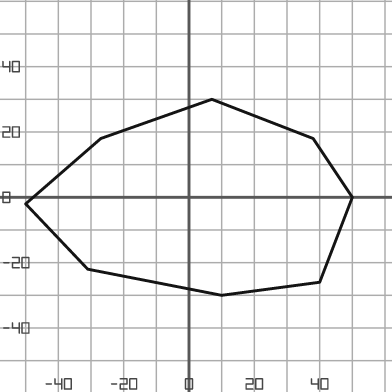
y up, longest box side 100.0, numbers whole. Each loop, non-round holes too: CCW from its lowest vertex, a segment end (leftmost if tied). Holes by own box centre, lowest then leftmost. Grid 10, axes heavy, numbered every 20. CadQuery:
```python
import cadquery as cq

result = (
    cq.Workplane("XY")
    .moveTo(10.0, -30.0)
    .lineTo(40.0, -26.0)
    .lineTo(50.0, 0.0)
    .lineTo(38.0, 18.0)
    .lineTo(7.0, 30.0)
    .lineTo(-27.0, 18.0)
    .lineTo(-50.0, -2.0)
    .lineTo(-31.0, -22.0)
    .close()
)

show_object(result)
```